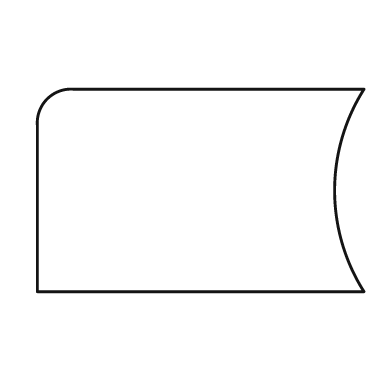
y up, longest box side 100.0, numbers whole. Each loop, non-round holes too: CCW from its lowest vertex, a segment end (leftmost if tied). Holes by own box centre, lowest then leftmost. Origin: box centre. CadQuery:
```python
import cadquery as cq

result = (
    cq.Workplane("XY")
    .moveTo(-50.0, -31.0)
    .lineTo(50.0, -31.0)
    .threePointArc((41.0, 0.0), (50.0, 31.0))
    .lineTo(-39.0, 31.0)
    .threePointArc((-47.0, 28.0), (-50.0, 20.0))
    .close()
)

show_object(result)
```